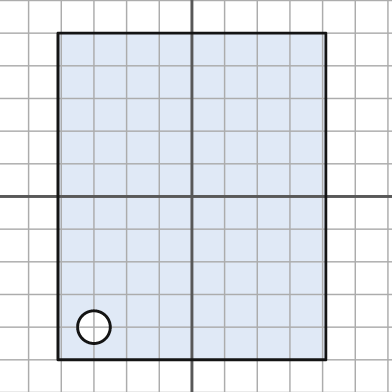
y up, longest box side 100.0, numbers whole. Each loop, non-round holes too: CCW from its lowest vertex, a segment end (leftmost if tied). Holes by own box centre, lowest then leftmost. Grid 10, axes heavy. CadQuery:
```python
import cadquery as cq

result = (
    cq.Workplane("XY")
    .moveTo(-41.0, -50.0)
    .lineTo(41.0, -50.0)
    .lineTo(41.0, 50.0)
    .lineTo(-41.0, 50.0)
    .close()
    .moveTo(-30.0, -40.0)
    .circle(5.0)
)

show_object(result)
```